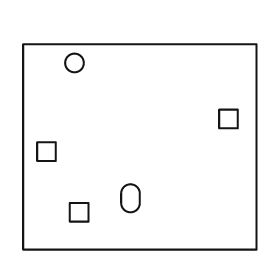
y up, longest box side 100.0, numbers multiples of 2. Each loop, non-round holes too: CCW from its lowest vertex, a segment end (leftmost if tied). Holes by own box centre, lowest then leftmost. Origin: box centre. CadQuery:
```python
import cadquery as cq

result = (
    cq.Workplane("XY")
    .moveTo(-50.0, -44.0)
    .lineTo(50.0, -44.0)
    .lineTo(50.0, 44.0)
    .lineTo(-50.0, 44.0)
    .close()
    .moveTo(-30.0, -32.0)
    .lineTo(-22.0, -32.0)
    .lineTo(-22.0, -24.0)
    .lineTo(-30.0, -24.0)
    .close()
    .moveTo(-8.0, -24.0)
    .threePointArc((-4.0, -28.0), (0.0, -24.0))
    .lineTo(0.0, -20.0)
    .threePointArc((-4.0, -16.0), (-8.0, -20.0))
    .close()
    .moveTo(-44.0, -6.0)
    .lineTo(-36.0, -6.0)
    .lineTo(-36.0, 2.0)
    .lineTo(-44.0, 2.0)
    .close()
    .moveTo(34.0, 8.0)
    .lineTo(42.0, 8.0)
    .lineTo(42.0, 16.0)
    .lineTo(34.0, 16.0)
    .close()
    .moveTo(-28.0, 36.0)
    .circle(4.0)
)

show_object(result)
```